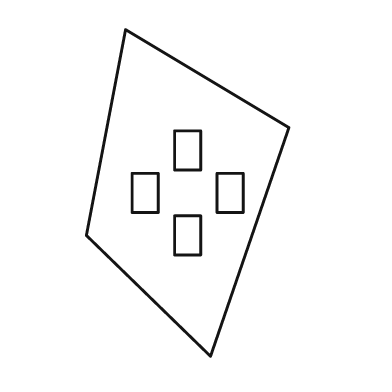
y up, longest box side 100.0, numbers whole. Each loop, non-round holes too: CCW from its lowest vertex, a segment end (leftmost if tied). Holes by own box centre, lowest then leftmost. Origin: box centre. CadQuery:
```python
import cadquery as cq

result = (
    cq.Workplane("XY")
    .moveTo(7.0, -50.0)
    .lineTo(31.0, 20.0)
    .lineTo(-19.0, 50.0)
    .lineTo(-31.0, -13.0)
    .close()
    .moveTo(-4.0, -19.0)
    .lineTo(4.0, -19.0)
    .lineTo(4.0, -7.0)
    .lineTo(-4.0, -7.0)
    .close()
    .moveTo(-17.0, -6.0)
    .lineTo(-9.0, -6.0)
    .lineTo(-9.0, 6.0)
    .lineTo(-17.0, 6.0)
    .close()
    .moveTo(9.0, -6.0)
    .lineTo(17.0, -6.0)
    .lineTo(17.0, 6.0)
    .lineTo(9.0, 6.0)
    .close()
    .moveTo(-4.0, 7.0)
    .lineTo(4.0, 7.0)
    .lineTo(4.0, 19.0)
    .lineTo(-4.0, 19.0)
    .close()
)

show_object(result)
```